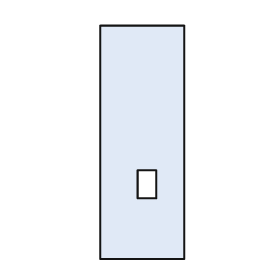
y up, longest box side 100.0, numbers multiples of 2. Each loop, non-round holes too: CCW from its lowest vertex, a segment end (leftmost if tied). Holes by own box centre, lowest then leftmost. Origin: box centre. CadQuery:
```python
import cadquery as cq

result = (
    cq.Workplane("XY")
    .moveTo(-18.0, -50.0)
    .lineTo(18.0, -50.0)
    .lineTo(18.0, 50.0)
    .lineTo(-18.0, 50.0)
    .close()
    .moveTo(-2.0, -24.0)
    .lineTo(6.0, -24.0)
    .lineTo(6.0, -12.0)
    .lineTo(-2.0, -12.0)
    .close()
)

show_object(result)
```